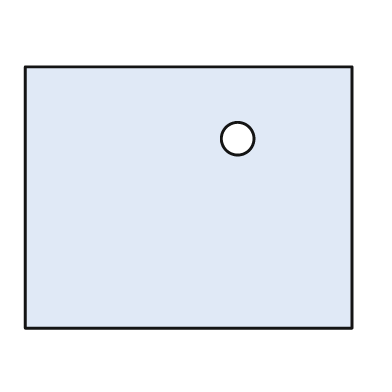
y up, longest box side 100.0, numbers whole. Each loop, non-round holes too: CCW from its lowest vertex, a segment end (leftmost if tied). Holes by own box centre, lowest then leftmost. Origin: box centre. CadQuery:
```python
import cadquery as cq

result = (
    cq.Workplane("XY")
    .moveTo(-50.0, -40.0)
    .lineTo(50.0, -40.0)
    .lineTo(50.0, 40.0)
    .lineTo(-50.0, 40.0)
    .close()
    .moveTo(15.0, 18.0)
    .circle(5.0)
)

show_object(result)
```